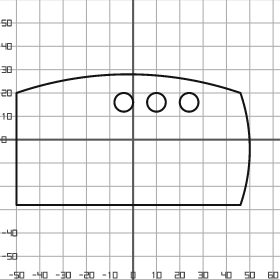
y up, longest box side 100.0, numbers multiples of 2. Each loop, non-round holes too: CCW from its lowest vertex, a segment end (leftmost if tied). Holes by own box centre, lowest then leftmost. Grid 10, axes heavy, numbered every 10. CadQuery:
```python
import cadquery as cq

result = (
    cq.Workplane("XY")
    .moveTo(-50.0, -28.0)
    .lineTo(46.0, -28.0)
    .threePointArc((50.0, -4.0), (46.0, 20.0))
    .threePointArc((-2.0, 28.0), (-50.0, 20.0))
    .close()
    .moveTo(-4.0, 16.0)
    .circle(4.0)
    .moveTo(10.0, 16.0)
    .circle(4.0)
    .moveTo(24.0, 16.0)
    .circle(4.0)
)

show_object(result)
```